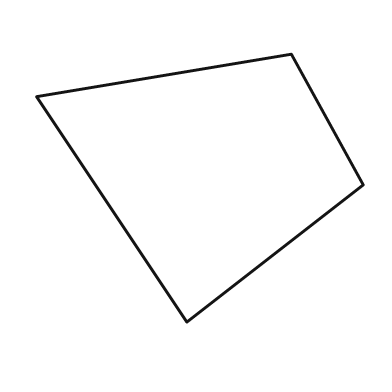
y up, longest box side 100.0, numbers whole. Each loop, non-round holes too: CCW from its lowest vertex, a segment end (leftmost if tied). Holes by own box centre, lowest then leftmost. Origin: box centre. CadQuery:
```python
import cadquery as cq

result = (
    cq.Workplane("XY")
    .moveTo(-4.0, -41.0)
    .lineTo(50.0, 1.0)
    .lineTo(28.0, 41.0)
    .lineTo(-50.0, 28.0)
    .close()
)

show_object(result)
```